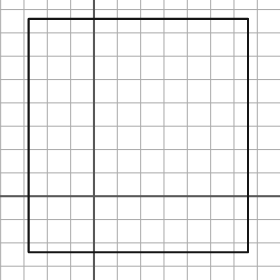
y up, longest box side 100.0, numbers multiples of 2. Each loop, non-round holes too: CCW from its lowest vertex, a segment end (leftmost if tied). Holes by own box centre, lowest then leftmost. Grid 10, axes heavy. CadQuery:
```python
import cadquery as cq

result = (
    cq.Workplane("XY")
    .moveTo(-28.0, -24.0)
    .lineTo(66.0, -24.0)
    .lineTo(66.0, 76.0)
    .lineTo(-28.0, 76.0)
    .close()
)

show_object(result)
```